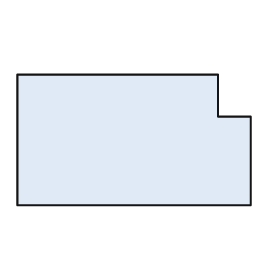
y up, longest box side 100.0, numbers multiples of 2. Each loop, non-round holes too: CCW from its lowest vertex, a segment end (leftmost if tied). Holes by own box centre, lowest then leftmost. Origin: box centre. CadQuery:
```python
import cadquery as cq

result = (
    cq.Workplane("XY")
    .moveTo(-50.0, -28.0)
    .lineTo(50.0, -28.0)
    .lineTo(50.0, 10.0)
    .lineTo(36.0, 10.0)
    .lineTo(36.0, 28.0)
    .lineTo(-50.0, 28.0)
    .close()
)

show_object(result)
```